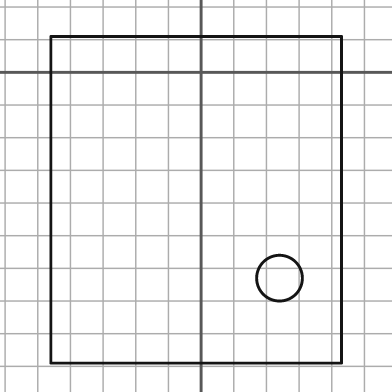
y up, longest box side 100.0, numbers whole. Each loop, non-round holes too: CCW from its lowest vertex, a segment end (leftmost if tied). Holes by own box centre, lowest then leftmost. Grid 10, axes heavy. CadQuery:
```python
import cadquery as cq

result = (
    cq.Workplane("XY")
    .moveTo(-46.0, -89.0)
    .lineTo(43.0, -89.0)
    .lineTo(43.0, 11.0)
    .lineTo(-46.0, 11.0)
    .close()
    .moveTo(24.0, -63.0)
    .circle(7.0)
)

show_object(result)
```